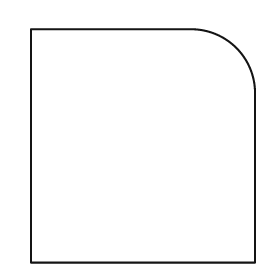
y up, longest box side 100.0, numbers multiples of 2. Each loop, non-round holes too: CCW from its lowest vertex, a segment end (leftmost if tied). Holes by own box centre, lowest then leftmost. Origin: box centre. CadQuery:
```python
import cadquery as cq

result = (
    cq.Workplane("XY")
    .moveTo(-48.0, -50.0)
    .lineTo(48.0, -50.0)
    .lineTo(48.0, 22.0)
    .threePointArc((40.0, 42.0), (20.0, 50.0))
    .lineTo(-48.0, 50.0)
    .close()
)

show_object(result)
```